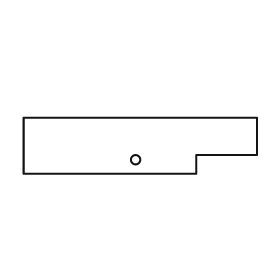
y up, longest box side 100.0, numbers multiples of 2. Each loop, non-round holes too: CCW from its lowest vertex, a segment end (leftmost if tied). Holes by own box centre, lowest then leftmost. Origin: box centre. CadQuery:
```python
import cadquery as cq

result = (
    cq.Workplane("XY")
    .moveTo(-50.0, -12.0)
    .lineTo(24.0, -12.0)
    .lineTo(24.0, -4.0)
    .lineTo(50.0, -4.0)
    .lineTo(50.0, 12.0)
    .lineTo(-50.0, 12.0)
    .close()
    .moveTo(-2.0, -6.0)
    .circle(2.0)
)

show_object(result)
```